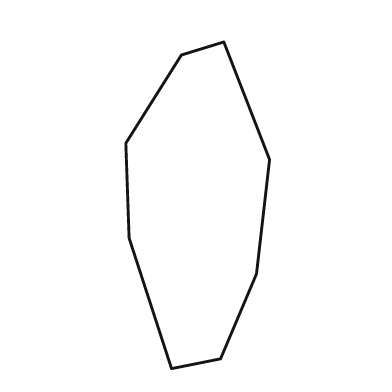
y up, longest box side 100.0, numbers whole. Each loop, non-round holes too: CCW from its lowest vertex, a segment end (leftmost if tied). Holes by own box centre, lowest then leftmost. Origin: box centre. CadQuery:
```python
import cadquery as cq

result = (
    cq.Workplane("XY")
    .moveTo(-8.0, -50.0)
    .lineTo(7.0, -47.0)
    .lineTo(18.0, -21.0)
    .lineTo(22.0, 14.0)
    .lineTo(8.0, 50.0)
    .lineTo(-5.0, 46.0)
    .lineTo(-22.0, 19.0)
    .lineTo(-21.0, -10.0)
    .close()
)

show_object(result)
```